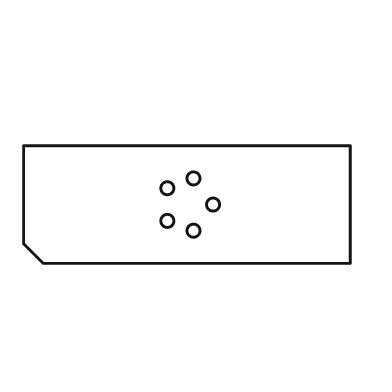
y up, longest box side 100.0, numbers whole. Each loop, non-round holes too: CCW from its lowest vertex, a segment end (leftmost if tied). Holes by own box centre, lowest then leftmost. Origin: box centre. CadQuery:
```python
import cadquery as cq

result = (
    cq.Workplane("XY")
    .moveTo(-44.0, -18.0)
    .lineTo(50.0, -18.0)
    .lineTo(50.0, 18.0)
    .lineTo(-50.0, 18.0)
    .lineTo(-50.0, -12.0)
    .close()
    .moveTo(2.0, -8.0)
    .circle(2.0)
    .moveTo(-6.0, -5.0)
    .circle(2.0)
    .moveTo(8.0, 0.0)
    .circle(2.0)
    .moveTo(-6.0, 5.0)
    .circle(2.0)
    .moveTo(2.0, 8.0)
    .circle(2.0)
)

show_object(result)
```